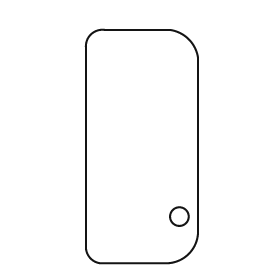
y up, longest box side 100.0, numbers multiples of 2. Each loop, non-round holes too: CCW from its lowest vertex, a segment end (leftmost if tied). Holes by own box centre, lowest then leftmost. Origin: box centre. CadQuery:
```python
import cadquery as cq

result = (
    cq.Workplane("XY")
    .moveTo(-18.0, -50.0)
    .lineTo(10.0, -50.0)
    .threePointArc((20.0, -46.0), (24.0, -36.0))
    .lineTo(24.0, 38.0)
    .threePointArc((20.0, 46.0), (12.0, 50.0))
    .lineTo(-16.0, 50.0)
    .threePointArc((-22.0, 48.0), (-24.0, 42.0))
    .lineTo(-24.0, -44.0)
    .threePointArc((-22.0, -48.0), (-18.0, -50.0))
    .close()
    .moveTo(16.0, -30.0)
    .circle(4.0)
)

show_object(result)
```